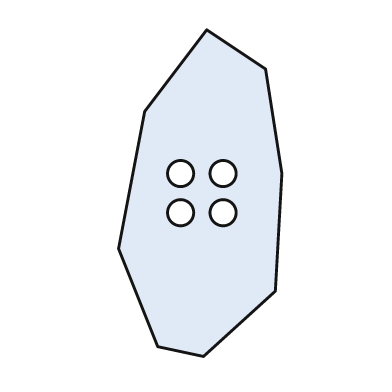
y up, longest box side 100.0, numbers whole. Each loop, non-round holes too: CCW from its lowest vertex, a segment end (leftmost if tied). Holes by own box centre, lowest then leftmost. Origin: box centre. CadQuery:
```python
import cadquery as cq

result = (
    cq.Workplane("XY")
    .moveTo(1.0, -50.0)
    .lineTo(23.0, -30.0)
    .lineTo(25.0, 6.0)
    .lineTo(20.0, 38.0)
    .lineTo(2.0, 50.0)
    .lineTo(-17.0, 25.0)
    .lineTo(-25.0, -17.0)
    .lineTo(-13.0, -47.0)
    .close()
    .moveTo(-6.0, -6.0)
    .circle(4.0)
    .moveTo(7.0, -6.0)
    .circle(4.0)
    .moveTo(-6.0, 6.0)
    .circle(4.0)
    .moveTo(7.0, 6.0)
    .circle(4.0)
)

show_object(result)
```